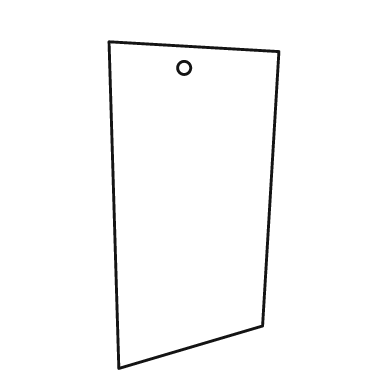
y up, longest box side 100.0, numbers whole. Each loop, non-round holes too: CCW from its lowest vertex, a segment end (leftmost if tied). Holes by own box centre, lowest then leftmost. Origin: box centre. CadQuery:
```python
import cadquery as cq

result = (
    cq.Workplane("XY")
    .moveTo(-23.0, -50.0)
    .lineTo(21.0, -37.0)
    .lineTo(26.0, 47.0)
    .lineTo(-26.0, 50.0)
    .close()
    .moveTo(-3.0, 42.0)
    .circle(2.0)
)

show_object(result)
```